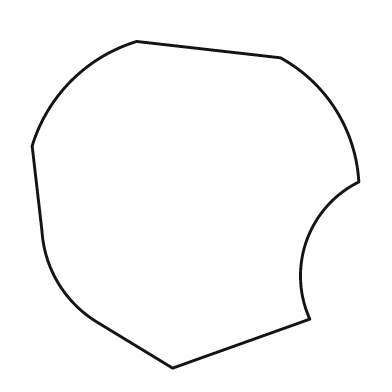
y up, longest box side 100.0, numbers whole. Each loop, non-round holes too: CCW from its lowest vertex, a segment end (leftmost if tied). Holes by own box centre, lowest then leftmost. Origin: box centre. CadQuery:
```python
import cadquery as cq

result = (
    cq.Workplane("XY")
    .moveTo(-7.0, -50.0)
    .lineTo(35.0, -35.0)
    .threePointArc((34.0, -11.0), (50.0, 7.0))
    .threePointArc((43.0, 29.0), (26.0, 45.0))
    .lineTo(-18.0, 50.0)
    .threePointArc((-38.0, 38.0), (-50.0, 18.0))
    .lineTo(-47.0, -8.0)
    .threePointArc((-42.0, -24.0), (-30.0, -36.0))
    .close()
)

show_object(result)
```